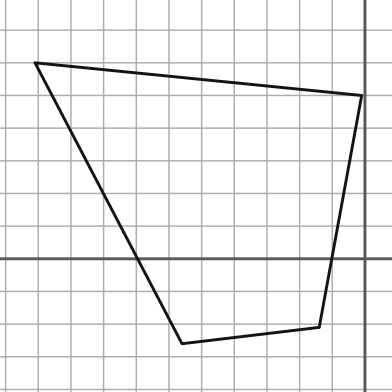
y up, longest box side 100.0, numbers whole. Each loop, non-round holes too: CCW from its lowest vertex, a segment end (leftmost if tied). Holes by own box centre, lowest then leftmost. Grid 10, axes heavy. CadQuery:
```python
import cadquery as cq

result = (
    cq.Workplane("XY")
    .moveTo(-56.0, -26.0)
    .lineTo(-14.0, -21.0)
    .lineTo(-1.0, 50.0)
    .lineTo(-101.0, 60.0)
    .close()
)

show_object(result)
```